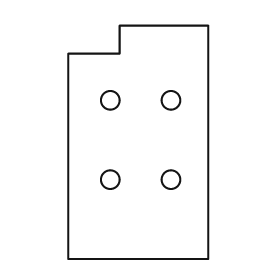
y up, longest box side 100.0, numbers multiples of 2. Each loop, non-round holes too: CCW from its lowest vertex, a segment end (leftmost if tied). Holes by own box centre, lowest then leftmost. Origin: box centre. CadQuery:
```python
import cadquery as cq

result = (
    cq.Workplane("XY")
    .moveTo(-30.0, -50.0)
    .lineTo(30.0, -50.0)
    .lineTo(30.0, 50.0)
    .lineTo(-8.0, 50.0)
    .lineTo(-8.0, 38.0)
    .lineTo(-30.0, 38.0)
    .close()
    .moveTo(-12.0, -16.0)
    .circle(4.0)
    .moveTo(14.0, -16.0)
    .circle(4.0)
    .moveTo(-12.0, 18.0)
    .circle(4.0)
    .moveTo(14.0, 18.0)
    .circle(4.0)
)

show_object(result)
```